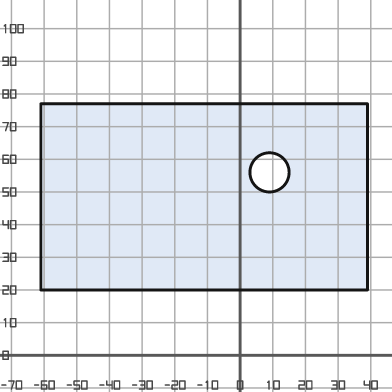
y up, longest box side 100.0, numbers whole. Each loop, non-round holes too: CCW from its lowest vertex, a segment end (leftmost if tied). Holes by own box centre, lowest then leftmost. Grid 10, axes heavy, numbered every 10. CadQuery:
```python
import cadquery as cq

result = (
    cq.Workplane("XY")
    .moveTo(-61.0, 20.0)
    .lineTo(39.0, 20.0)
    .lineTo(39.0, 77.0)
    .lineTo(-61.0, 77.0)
    .close()
    .moveTo(9.0, 56.0)
    .circle(6.0)
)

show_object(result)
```